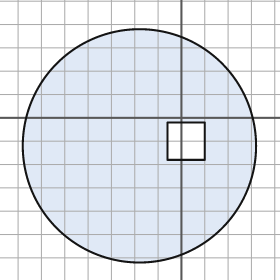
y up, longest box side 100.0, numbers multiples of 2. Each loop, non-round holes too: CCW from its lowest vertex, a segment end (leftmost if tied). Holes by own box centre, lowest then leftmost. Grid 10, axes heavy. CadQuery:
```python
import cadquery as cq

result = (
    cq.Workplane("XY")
    .moveTo(-18.0, -12.0)
    .circle(50.0)
    .moveTo(-6.0, -18.0)
    .lineTo(10.0, -18.0)
    .lineTo(10.0, -2.0)
    .lineTo(-6.0, -2.0)
    .close()
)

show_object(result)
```